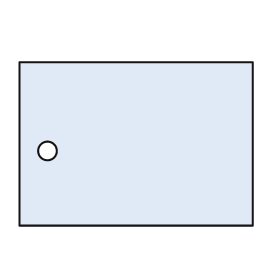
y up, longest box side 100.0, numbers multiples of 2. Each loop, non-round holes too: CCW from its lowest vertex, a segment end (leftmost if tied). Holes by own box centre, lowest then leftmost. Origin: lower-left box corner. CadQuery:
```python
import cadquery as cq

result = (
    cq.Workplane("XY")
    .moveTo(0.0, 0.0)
    .lineTo(100.0, 0.0)
    .lineTo(100.0, 70.0)
    .lineTo(0.0, 70.0)
    .close()
    .moveTo(12.0, 32.0)
    .circle(4.0)
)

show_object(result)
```